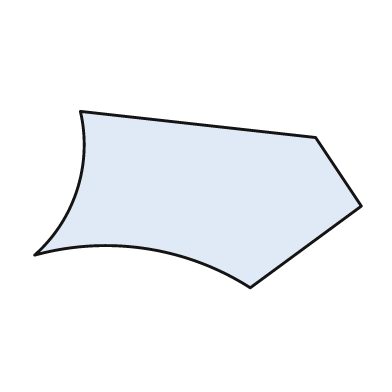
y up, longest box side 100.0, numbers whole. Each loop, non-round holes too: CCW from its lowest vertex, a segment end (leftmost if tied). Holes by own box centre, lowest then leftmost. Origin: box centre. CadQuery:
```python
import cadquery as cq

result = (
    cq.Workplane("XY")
    .moveTo(16.0, -27.0)
    .lineTo(50.0, -2.0)
    .lineTo(36.0, 19.0)
    .lineTo(-36.0, 27.0)
    .threePointArc((-37.0, 3.0), (-50.0, -17.0))
    .threePointArc((-16.0, -15.0), (16.0, -27.0))
    .close()
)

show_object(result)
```